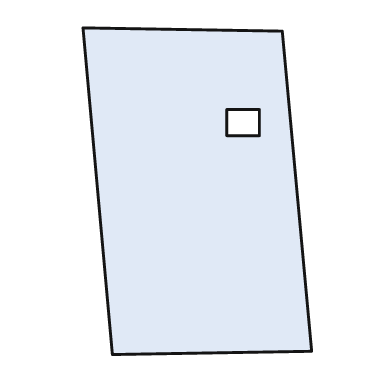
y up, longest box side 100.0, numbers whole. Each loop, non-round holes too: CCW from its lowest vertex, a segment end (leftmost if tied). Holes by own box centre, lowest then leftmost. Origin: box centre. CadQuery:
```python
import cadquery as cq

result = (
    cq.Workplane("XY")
    .moveTo(-26.0, -50.0)
    .lineTo(35.0, -49.0)
    .lineTo(26.0, 49.0)
    .lineTo(-35.0, 50.0)
    .close()
    .moveTo(9.0, 17.0)
    .lineTo(19.0, 17.0)
    .lineTo(19.0, 25.0)
    .lineTo(9.0, 25.0)
    .close()
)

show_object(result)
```